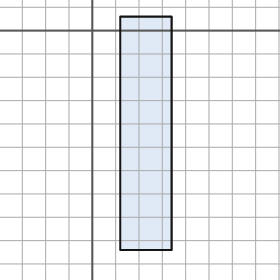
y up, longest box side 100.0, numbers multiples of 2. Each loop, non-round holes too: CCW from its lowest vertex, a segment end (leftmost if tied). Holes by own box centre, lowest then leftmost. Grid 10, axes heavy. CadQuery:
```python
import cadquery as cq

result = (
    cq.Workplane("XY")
    .moveTo(12.0, -94.0)
    .lineTo(34.0, -94.0)
    .lineTo(34.0, 6.0)
    .lineTo(12.0, 6.0)
    .close()
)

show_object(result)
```